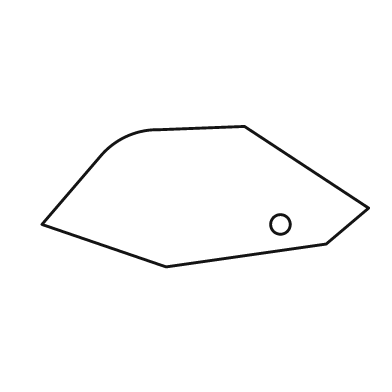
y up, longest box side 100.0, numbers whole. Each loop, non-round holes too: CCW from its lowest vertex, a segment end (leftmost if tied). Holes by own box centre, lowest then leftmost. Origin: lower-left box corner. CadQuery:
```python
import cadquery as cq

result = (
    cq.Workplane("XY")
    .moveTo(38.0, 0.0)
    .lineTo(87.0, 7.0)
    .lineTo(100.0, 18.0)
    .lineTo(62.0, 43.0)
    .lineTo(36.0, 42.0)
    .threePointArc((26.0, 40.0), (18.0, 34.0))
    .lineTo(0.0, 13.0)
    .close()
    .moveTo(73.0, 13.0)
    .circle(3.0)
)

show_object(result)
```